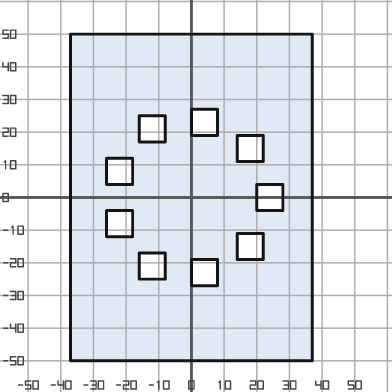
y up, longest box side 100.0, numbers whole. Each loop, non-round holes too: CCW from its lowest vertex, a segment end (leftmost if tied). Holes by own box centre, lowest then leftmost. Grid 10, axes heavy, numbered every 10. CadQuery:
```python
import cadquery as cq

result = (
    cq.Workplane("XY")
    .moveTo(-37.0, -50.0)
    .lineTo(37.0, -50.0)
    .lineTo(37.0, 50.0)
    .lineTo(-37.0, 50.0)
    .close()
    .moveTo(0.0, -27.0)
    .lineTo(8.0, -27.0)
    .lineTo(8.0, -19.0)
    .lineTo(0.0, -19.0)
    .close()
    .moveTo(-16.0, -25.0)
    .lineTo(-8.0, -25.0)
    .lineTo(-8.0, -17.0)
    .lineTo(-16.0, -17.0)
    .close()
    .moveTo(14.0, -19.0)
    .lineTo(22.0, -19.0)
    .lineTo(22.0, -11.0)
    .lineTo(14.0, -11.0)
    .close()
    .moveTo(-26.0, -12.0)
    .lineTo(-18.0, -12.0)
    .lineTo(-18.0, -4.0)
    .lineTo(-26.0, -4.0)
    .close()
    .moveTo(20.0, -4.0)
    .lineTo(28.0, -4.0)
    .lineTo(28.0, 4.0)
    .lineTo(20.0, 4.0)
    .close()
    .moveTo(-26.0, 4.0)
    .lineTo(-18.0, 4.0)
    .lineTo(-18.0, 12.0)
    .lineTo(-26.0, 12.0)
    .close()
    .moveTo(14.0, 11.0)
    .lineTo(22.0, 11.0)
    .lineTo(22.0, 19.0)
    .lineTo(14.0, 19.0)
    .close()
    .moveTo(-16.0, 17.0)
    .lineTo(-8.0, 17.0)
    .lineTo(-8.0, 25.0)
    .lineTo(-16.0, 25.0)
    .close()
    .moveTo(0.0, 19.0)
    .lineTo(8.0, 19.0)
    .lineTo(8.0, 27.0)
    .lineTo(0.0, 27.0)
    .close()
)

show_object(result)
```